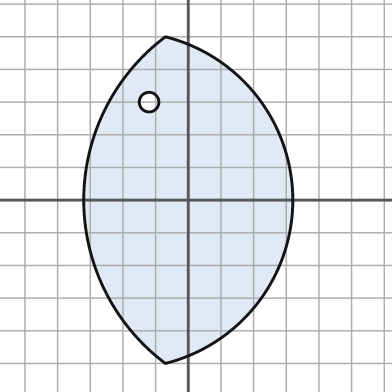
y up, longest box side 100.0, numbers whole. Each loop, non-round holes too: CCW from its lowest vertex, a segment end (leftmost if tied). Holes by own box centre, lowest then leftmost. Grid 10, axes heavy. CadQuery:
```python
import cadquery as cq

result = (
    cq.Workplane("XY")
    .moveTo(-7.0, -50.0)
    .threePointArc((32.0, 0.0), (-7.0, 50.0))
    .threePointArc((-32.0, 0.0), (-7.0, -50.0))
    .close()
    .moveTo(-12.0, 30.0)
    .circle(3.0)
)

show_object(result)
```